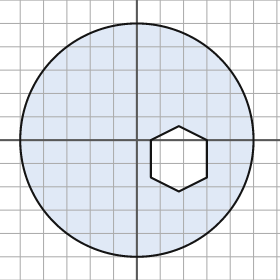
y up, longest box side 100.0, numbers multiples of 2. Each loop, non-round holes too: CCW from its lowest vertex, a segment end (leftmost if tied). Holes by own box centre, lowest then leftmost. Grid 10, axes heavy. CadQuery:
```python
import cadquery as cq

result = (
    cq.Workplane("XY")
    .moveTo(0.0, 0.0)
    .circle(50.0)
    .moveTo(18.0, -22.0)
    .lineTo(30.0, -16.0)
    .lineTo(30.0, 0.0)
    .lineTo(18.0, 6.0)
    .lineTo(6.0, 0.0)
    .lineTo(6.0, -16.0)
    .close()
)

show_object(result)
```